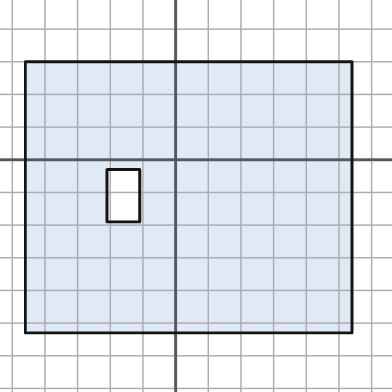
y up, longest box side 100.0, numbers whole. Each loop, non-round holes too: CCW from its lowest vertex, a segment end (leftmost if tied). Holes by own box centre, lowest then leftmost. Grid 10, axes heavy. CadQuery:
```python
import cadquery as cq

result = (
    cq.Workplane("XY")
    .moveTo(-46.0, -53.0)
    .lineTo(54.0, -53.0)
    .lineTo(54.0, 30.0)
    .lineTo(-46.0, 30.0)
    .close()
    .moveTo(-21.0, -19.0)
    .lineTo(-11.0, -19.0)
    .lineTo(-11.0, -3.0)
    .lineTo(-21.0, -3.0)
    .close()
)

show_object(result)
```